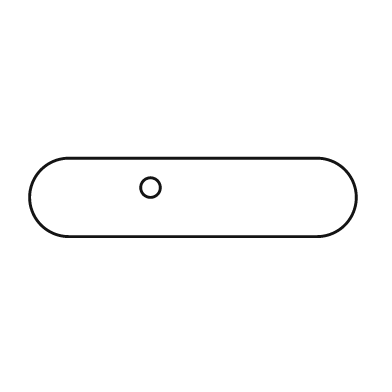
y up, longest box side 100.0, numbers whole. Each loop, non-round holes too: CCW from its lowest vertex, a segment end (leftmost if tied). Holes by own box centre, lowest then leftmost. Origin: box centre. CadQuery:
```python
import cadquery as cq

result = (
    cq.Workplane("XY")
    .moveTo(-38.0, -12.0)
    .lineTo(38.0, -12.0)
    .threePointArc((50.0, 0.0), (38.0, 12.0))
    .lineTo(-38.0, 12.0)
    .threePointArc((-50.0, 0.0), (-38.0, -12.0))
    .close()
    .moveTo(-13.0, 3.0)
    .circle(3.0)
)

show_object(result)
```